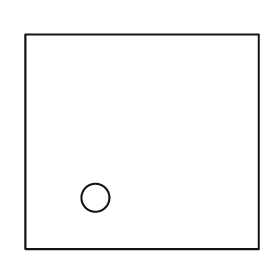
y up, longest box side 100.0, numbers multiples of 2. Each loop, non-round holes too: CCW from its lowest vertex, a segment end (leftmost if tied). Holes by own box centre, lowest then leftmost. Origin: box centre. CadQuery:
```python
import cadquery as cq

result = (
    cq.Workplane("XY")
    .moveTo(-50.0, -46.0)
    .lineTo(50.0, -46.0)
    .lineTo(50.0, 46.0)
    .lineTo(-50.0, 46.0)
    .close()
    .moveTo(-20.0, -24.0)
    .circle(6.0)
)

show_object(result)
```